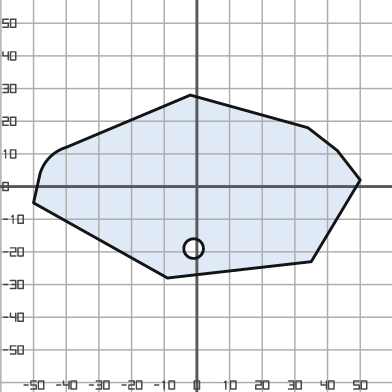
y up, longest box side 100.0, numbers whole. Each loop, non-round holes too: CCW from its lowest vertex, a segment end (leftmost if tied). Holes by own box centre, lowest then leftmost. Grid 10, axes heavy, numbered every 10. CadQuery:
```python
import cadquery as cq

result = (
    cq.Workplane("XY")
    .moveTo(-9.0, -28.0)
    .lineTo(35.0, -23.0)
    .lineTo(50.0, 2.0)
    .lineTo(43.0, 11.0)
    .lineTo(34.0, 18.0)
    .lineTo(-2.0, 28.0)
    .lineTo(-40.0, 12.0)
    .threePointArc((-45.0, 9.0), (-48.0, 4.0))
    .lineTo(-50.0, -5.0)
    .close()
    .moveTo(-1.0, -19.0)
    .circle(3.0)
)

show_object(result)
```